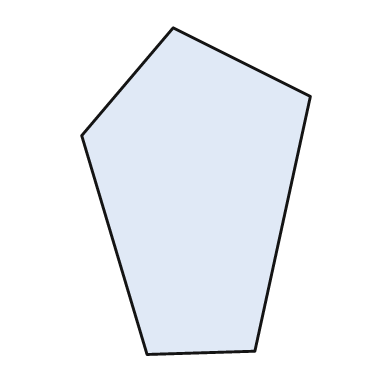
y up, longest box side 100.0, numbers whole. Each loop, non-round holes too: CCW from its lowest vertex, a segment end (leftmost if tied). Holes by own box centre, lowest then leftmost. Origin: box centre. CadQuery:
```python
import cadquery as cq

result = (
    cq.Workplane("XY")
    .moveTo(-15.0, -50.0)
    .lineTo(18.0, -49.0)
    .lineTo(35.0, 29.0)
    .lineTo(-7.0, 50.0)
    .lineTo(-35.0, 17.0)
    .close()
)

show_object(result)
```